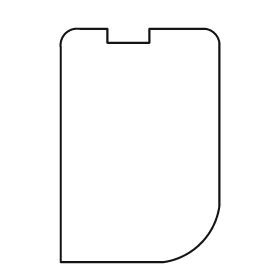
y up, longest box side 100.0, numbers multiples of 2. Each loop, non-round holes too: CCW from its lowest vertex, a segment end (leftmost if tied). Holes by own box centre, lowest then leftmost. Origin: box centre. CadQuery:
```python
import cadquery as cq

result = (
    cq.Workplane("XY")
    .moveTo(-34.0, -50.0)
    .lineTo(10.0, -50.0)
    .threePointArc((26.0, -42.0), (34.0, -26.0))
    .lineTo(34.0, 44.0)
    .threePointArc((32.0, 48.0), (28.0, 50.0))
    .lineTo(4.0, 50.0)
    .lineTo(4.0, 44.0)
    .lineTo(-14.0, 44.0)
    .lineTo(-14.0, 50.0)
    .lineTo(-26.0, 50.0)
    .threePointArc((-32.0, 48.0), (-34.0, 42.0))
    .close()
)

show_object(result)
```